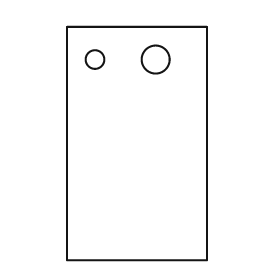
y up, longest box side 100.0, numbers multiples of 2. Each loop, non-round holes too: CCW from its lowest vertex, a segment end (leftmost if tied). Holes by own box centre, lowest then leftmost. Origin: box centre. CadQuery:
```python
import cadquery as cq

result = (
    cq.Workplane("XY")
    .moveTo(-30.0, -50.0)
    .lineTo(30.0, -50.0)
    .lineTo(30.0, 50.0)
    .lineTo(-30.0, 50.0)
    .close()
    .moveTo(-18.0, 36.0)
    .circle(4.0)
    .moveTo(8.0, 36.0)
    .circle(6.0)
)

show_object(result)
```